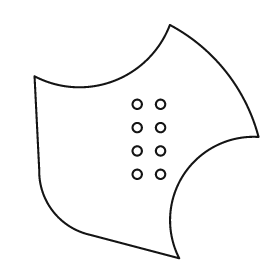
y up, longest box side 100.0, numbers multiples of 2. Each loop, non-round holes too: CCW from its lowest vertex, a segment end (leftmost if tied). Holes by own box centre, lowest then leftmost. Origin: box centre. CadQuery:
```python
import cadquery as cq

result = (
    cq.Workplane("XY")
    .moveTo(14.0, -50.0)
    .threePointArc((16.0, -14.0), (48.0, 2.0))
    .threePointArc((34.0, 30.0), (10.0, 50.0))
    .threePointArc((-14.0, 26.0), (-48.0, 28.0))
    .lineTo(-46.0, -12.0)
    .threePointArc((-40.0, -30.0), (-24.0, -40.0))
    .close()
    .moveTo(-4.0, -14.0)
    .circle(2.0)
    .moveTo(6.0, -14.0)
    .circle(2.0)
    .moveTo(-4.0, -4.0)
    .circle(2.0)
    .moveTo(6.0, -4.0)
    .circle(2.0)
    .moveTo(-4.0, 6.0)
    .circle(2.0)
    .moveTo(6.0, 6.0)
    .circle(2.0)
    .moveTo(-4.0, 16.0)
    .circle(2.0)
    .moveTo(6.0, 16.0)
    .circle(2.0)
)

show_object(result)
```